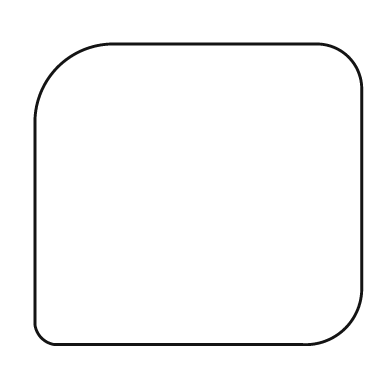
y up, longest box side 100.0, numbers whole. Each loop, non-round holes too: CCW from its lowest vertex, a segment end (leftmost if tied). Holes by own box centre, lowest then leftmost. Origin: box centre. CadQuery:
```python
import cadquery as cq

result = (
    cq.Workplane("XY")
    .moveTo(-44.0, -46.0)
    .lineTo(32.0, -46.0)
    .threePointArc((45.0, -41.0), (50.0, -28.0))
    .lineTo(50.0, 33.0)
    .threePointArc((46.0, 42.0), (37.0, 46.0))
    .lineTo(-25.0, 46.0)
    .threePointArc((-43.0, 39.0), (-50.0, 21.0))
    .lineTo(-50.0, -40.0)
    .threePointArc((-48.0, -44.0), (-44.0, -46.0))
    .close()
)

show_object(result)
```